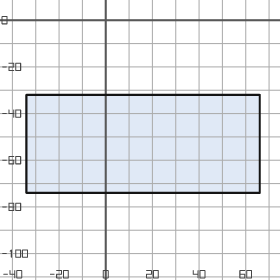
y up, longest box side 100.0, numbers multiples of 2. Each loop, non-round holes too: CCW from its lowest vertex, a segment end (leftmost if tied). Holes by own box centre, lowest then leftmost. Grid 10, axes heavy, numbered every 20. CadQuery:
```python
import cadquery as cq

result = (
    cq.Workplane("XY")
    .moveTo(-34.0, -74.0)
    .lineTo(66.0, -74.0)
    .lineTo(66.0, -32.0)
    .lineTo(-34.0, -32.0)
    .close()
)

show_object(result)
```